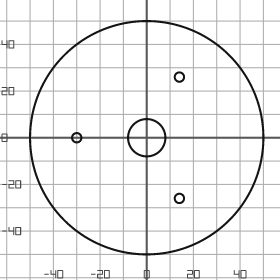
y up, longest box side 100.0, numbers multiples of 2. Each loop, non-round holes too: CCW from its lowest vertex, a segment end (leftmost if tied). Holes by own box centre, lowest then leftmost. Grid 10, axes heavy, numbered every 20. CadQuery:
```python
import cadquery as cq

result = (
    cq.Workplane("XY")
    .moveTo(0.0, 0.0)
    .circle(50.0)
    .moveTo(14.0, -26.0)
    .circle(2.0)
    .moveTo(-30.0, 0.0)
    .circle(2.0)
    .moveTo(0.0, 0.0)
    .circle(8.0)
    .moveTo(14.0, 26.0)
    .circle(2.0)
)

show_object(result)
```